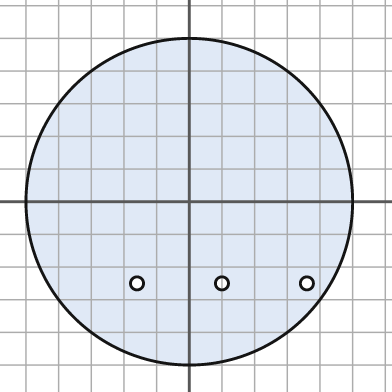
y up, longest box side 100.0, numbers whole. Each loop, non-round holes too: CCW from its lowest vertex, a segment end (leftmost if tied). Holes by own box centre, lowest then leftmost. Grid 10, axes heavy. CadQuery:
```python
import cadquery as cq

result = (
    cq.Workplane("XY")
    .moveTo(0.0, 0.0)
    .circle(50.0)
    .moveTo(-16.0, -25.0)
    .circle(2.0)
    .moveTo(10.0, -25.0)
    .circle(2.0)
    .moveTo(36.0, -25.0)
    .circle(2.0)
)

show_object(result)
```